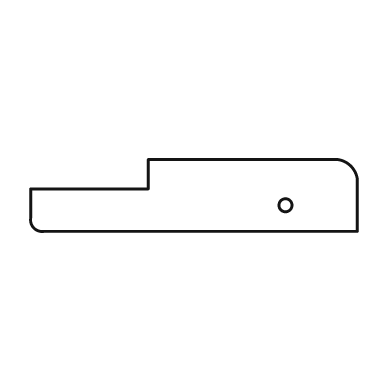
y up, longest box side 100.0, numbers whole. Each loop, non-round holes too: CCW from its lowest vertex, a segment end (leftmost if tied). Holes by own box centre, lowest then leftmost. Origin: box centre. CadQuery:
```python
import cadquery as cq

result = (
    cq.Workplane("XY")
    .moveTo(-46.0, -11.0)
    .lineTo(50.0, -11.0)
    .lineTo(50.0, 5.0)
    .threePointArc((48.0, 9.0), (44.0, 11.0))
    .lineTo(-14.0, 11.0)
    .lineTo(-14.0, 2.0)
    .lineTo(-50.0, 2.0)
    .lineTo(-50.0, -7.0)
    .threePointArc((-49.0, -10.0), (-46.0, -11.0))
    .close()
    .moveTo(28.0, -3.0)
    .circle(2.0)
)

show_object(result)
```